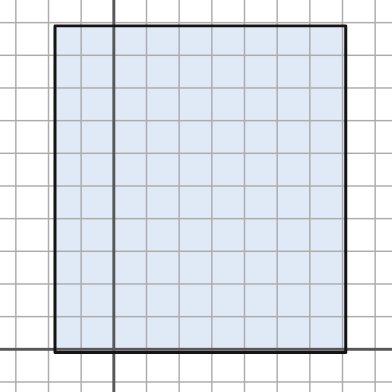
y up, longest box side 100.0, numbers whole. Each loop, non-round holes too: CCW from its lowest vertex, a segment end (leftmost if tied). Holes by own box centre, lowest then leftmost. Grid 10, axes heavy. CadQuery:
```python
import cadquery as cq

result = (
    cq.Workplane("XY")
    .moveTo(-18.0, -1.0)
    .lineTo(71.0, -1.0)
    .lineTo(71.0, 99.0)
    .lineTo(-18.0, 99.0)
    .close()
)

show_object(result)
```